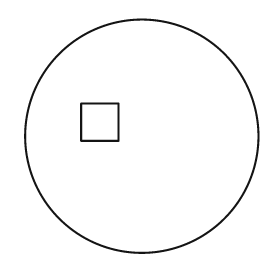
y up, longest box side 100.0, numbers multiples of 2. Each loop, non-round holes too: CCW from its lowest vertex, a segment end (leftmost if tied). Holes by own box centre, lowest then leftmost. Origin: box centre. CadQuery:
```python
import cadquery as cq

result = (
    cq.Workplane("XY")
    .moveTo(0.0, 0.0)
    .circle(50.0)
    .moveTo(-26.0, -2.0)
    .lineTo(-10.0, -2.0)
    .lineTo(-10.0, 14.0)
    .lineTo(-26.0, 14.0)
    .close()
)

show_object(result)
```